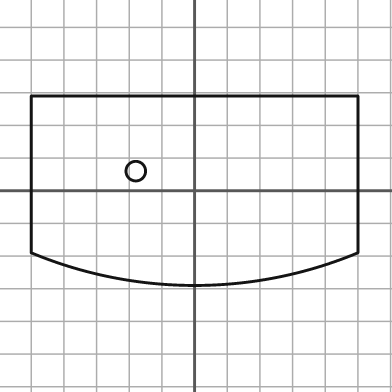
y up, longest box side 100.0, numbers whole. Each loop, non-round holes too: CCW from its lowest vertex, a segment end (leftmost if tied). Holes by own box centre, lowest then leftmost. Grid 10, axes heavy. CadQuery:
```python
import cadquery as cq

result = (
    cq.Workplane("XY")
    .moveTo(-50.0, -19.0)
    .threePointArc((0.0, -29.0), (50.0, -19.0))
    .lineTo(50.0, 29.0)
    .lineTo(-50.0, 29.0)
    .close()
    .moveTo(-18.0, 6.0)
    .circle(3.0)
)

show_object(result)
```